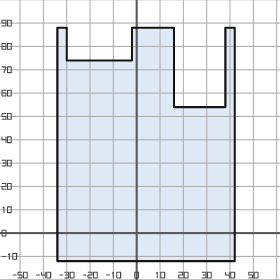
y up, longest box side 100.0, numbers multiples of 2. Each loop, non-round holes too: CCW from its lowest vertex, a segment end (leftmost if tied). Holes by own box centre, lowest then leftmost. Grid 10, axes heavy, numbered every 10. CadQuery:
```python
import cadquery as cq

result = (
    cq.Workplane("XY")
    .moveTo(-34.0, -12.0)
    .lineTo(42.0, -12.0)
    .lineTo(42.0, 88.0)
    .lineTo(38.0, 88.0)
    .lineTo(38.0, 54.0)
    .lineTo(16.0, 54.0)
    .lineTo(16.0, 88.0)
    .lineTo(-2.0, 88.0)
    .lineTo(-2.0, 74.0)
    .lineTo(-30.0, 74.0)
    .lineTo(-30.0, 88.0)
    .lineTo(-34.0, 88.0)
    .close()
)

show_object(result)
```